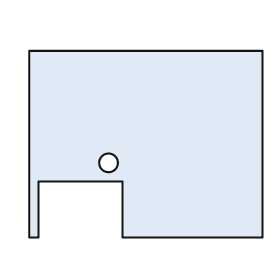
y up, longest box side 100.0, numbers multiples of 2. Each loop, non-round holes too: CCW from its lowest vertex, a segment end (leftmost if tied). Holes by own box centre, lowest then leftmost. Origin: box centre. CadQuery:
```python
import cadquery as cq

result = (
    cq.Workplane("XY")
    .moveTo(-50.0, -40.0)
    .lineTo(-46.0, -40.0)
    .lineTo(-46.0, -16.0)
    .lineTo(-10.0, -16.0)
    .lineTo(-10.0, -40.0)
    .lineTo(50.0, -40.0)
    .lineTo(50.0, 40.0)
    .lineTo(-50.0, 40.0)
    .close()
    .moveTo(-16.0, -8.0)
    .circle(4.0)
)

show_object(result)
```